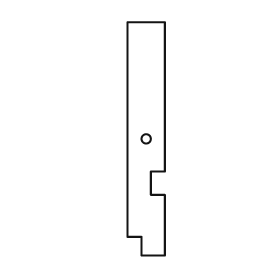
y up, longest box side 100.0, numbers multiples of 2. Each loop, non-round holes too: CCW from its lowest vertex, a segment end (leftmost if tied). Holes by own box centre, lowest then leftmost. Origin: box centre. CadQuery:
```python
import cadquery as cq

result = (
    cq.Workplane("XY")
    .moveTo(-2.0, -50.0)
    .lineTo(8.0, -50.0)
    .lineTo(8.0, -24.0)
    .lineTo(2.0, -24.0)
    .lineTo(2.0, -14.0)
    .lineTo(8.0, -14.0)
    .lineTo(8.0, 50.0)
    .lineTo(-8.0, 50.0)
    .lineTo(-8.0, -42.0)
    .lineTo(-2.0, -42.0)
    .close()
    .moveTo(0.0, 0.0)
    .circle(2.0)
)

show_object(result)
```